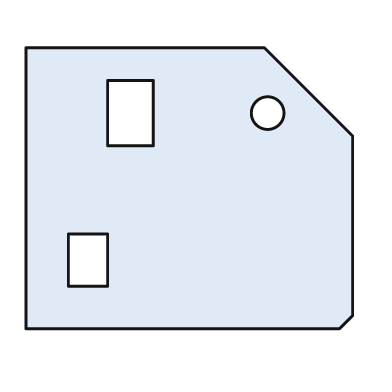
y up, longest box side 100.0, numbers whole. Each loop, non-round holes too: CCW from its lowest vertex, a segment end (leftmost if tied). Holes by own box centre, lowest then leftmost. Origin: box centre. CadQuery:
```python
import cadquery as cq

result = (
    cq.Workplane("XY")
    .moveTo(-50.0, -43.0)
    .lineTo(46.0, -43.0)
    .lineTo(50.0, -39.0)
    .lineTo(50.0, 16.0)
    .lineTo(23.0, 43.0)
    .lineTo(-50.0, 43.0)
    .close()
    .moveTo(-37.0, -30.0)
    .lineTo(-25.0, -30.0)
    .lineTo(-25.0, -14.0)
    .lineTo(-37.0, -14.0)
    .close()
    .moveTo(-25.0, 13.0)
    .lineTo(-11.0, 13.0)
    .lineTo(-11.0, 33.0)
    .lineTo(-25.0, 33.0)
    .close()
    .moveTo(24.0, 23.0)
    .circle(5.0)
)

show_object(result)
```